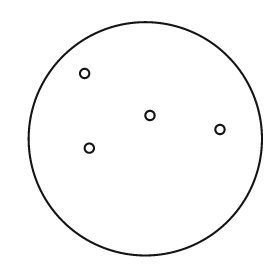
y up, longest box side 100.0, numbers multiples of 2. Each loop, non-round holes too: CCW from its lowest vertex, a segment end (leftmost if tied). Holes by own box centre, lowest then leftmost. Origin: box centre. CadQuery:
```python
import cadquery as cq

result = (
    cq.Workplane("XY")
    .moveTo(0.0, 0.0)
    .circle(50.0)
    .moveTo(-24.0, -4.0)
    .circle(2.0)
    .moveTo(32.0, 4.0)
    .circle(2.0)
    .moveTo(2.0, 10.0)
    .circle(2.0)
    .moveTo(-26.0, 28.0)
    .circle(2.0)
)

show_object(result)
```